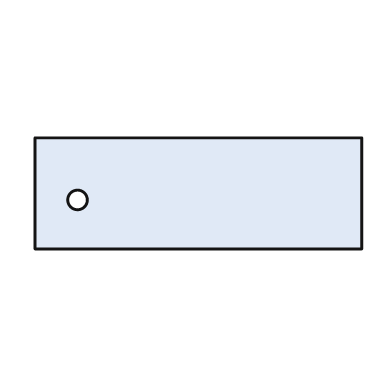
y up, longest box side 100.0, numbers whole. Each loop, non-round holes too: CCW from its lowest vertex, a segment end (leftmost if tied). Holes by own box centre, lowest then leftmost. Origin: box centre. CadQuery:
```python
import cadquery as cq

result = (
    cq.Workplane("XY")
    .moveTo(-50.0, -17.0)
    .lineTo(50.0, -17.0)
    .lineTo(50.0, 17.0)
    .lineTo(-50.0, 17.0)
    .close()
    .moveTo(-37.0, -2.0)
    .circle(3.0)
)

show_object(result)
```